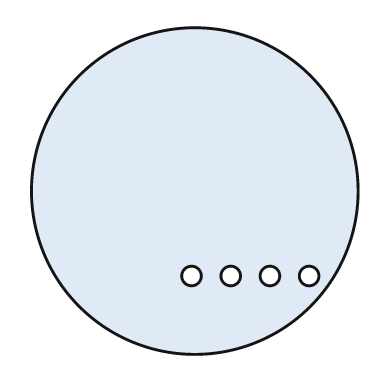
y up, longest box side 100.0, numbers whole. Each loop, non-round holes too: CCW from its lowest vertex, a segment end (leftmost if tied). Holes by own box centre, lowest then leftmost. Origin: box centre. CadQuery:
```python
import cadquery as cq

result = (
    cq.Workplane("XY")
    .moveTo(0.0, 0.0)
    .circle(50.0)
    .moveTo(-1.0, -26.0)
    .circle(3.0)
    .moveTo(11.0, -26.0)
    .circle(3.0)
    .moveTo(23.0, -26.0)
    .circle(3.0)
    .moveTo(35.0, -26.0)
    .circle(3.0)
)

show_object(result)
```